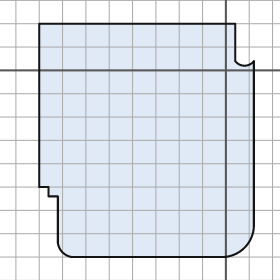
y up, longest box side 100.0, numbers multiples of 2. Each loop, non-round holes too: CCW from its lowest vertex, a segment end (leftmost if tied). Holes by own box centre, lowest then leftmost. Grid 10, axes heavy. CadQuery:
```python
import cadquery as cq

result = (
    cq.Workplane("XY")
    .moveTo(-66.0, -80.0)
    .lineTo(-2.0, -80.0)
    .threePointArc((8.0, -76.0), (12.0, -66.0))
    .lineTo(12.0, 4.0)
    .threePointArc((8.0, 2.0), (4.0, 4.0))
    .lineTo(4.0, 20.0)
    .lineTo(-80.0, 20.0)
    .lineTo(-80.0, -50.0)
    .lineTo(-76.0, -50.0)
    .lineTo(-76.0, -54.0)
    .lineTo(-72.0, -54.0)
    .lineTo(-72.0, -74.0)
    .threePointArc((-70.0, -78.0), (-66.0, -80.0))
    .close()
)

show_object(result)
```